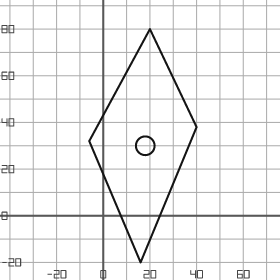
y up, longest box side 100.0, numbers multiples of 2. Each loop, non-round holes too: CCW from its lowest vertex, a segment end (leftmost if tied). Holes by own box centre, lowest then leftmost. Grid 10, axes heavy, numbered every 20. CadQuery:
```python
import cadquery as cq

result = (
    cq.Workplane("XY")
    .moveTo(16.0, -20.0)
    .lineTo(40.0, 38.0)
    .lineTo(20.0, 80.0)
    .lineTo(-6.0, 32.0)
    .close()
    .moveTo(18.0, 30.0)
    .circle(4.0)
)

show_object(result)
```